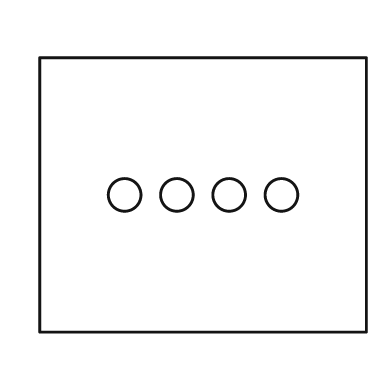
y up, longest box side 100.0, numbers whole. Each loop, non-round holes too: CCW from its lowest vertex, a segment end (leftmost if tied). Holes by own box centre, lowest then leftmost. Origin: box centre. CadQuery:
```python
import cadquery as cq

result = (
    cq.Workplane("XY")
    .moveTo(-50.0, -42.0)
    .lineTo(50.0, -42.0)
    .lineTo(50.0, 42.0)
    .lineTo(-50.0, 42.0)
    .close()
    .moveTo(-24.0, 0.0)
    .circle(5.0)
    .moveTo(-8.0, 0.0)
    .circle(5.0)
    .moveTo(8.0, 0.0)
    .circle(5.0)
    .moveTo(24.0, 0.0)
    .circle(5.0)
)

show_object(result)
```